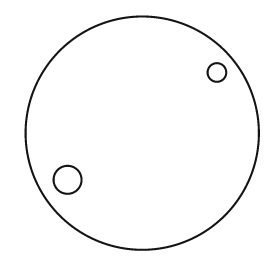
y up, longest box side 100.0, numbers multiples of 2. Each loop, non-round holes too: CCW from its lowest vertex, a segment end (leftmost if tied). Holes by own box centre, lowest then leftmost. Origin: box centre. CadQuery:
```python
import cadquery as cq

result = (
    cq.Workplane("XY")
    .moveTo(0.0, 0.0)
    .circle(50.0)
    .moveTo(-32.0, -20.0)
    .circle(6.0)
    .moveTo(32.0, 26.0)
    .circle(4.0)
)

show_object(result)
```